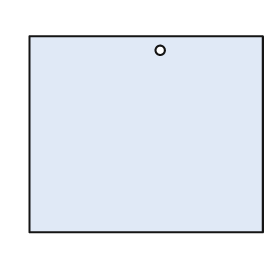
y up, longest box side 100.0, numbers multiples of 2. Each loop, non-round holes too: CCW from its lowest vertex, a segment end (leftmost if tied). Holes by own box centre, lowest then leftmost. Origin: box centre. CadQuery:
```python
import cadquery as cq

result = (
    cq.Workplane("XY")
    .moveTo(-50.0, -42.0)
    .lineTo(50.0, -42.0)
    .lineTo(50.0, 42.0)
    .lineTo(-50.0, 42.0)
    .close()
    .moveTo(6.0, 36.0)
    .circle(2.0)
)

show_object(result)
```